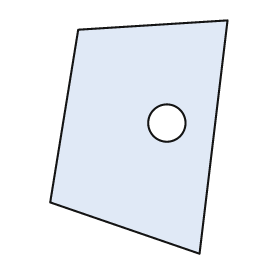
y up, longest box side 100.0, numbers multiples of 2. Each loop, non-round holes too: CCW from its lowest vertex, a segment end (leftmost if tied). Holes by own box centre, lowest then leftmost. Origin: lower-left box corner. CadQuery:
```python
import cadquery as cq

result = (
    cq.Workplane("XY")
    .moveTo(64.0, 0.0)
    .lineTo(76.0, 100.0)
    .lineTo(12.0, 96.0)
    .lineTo(0.0, 22.0)
    .close()
    .moveTo(50.0, 56.0)
    .circle(8.0)
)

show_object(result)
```